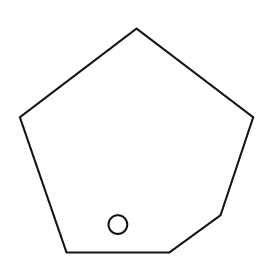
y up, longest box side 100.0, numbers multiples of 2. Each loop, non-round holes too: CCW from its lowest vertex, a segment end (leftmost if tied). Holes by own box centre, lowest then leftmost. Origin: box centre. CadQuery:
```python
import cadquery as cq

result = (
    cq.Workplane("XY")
    .moveTo(-30.0, -48.0)
    .lineTo(14.0, -48.0)
    .lineTo(36.0, -32.0)
    .lineTo(50.0, 10.0)
    .lineTo(0.0, 48.0)
    .lineTo(-50.0, 10.0)
    .close()
    .moveTo(-8.0, -36.0)
    .circle(4.0)
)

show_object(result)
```